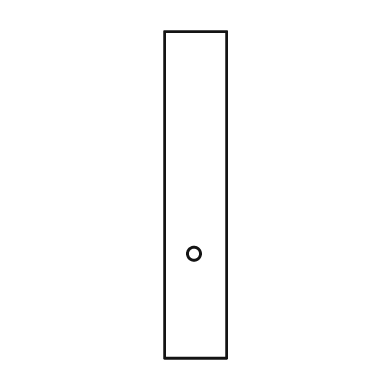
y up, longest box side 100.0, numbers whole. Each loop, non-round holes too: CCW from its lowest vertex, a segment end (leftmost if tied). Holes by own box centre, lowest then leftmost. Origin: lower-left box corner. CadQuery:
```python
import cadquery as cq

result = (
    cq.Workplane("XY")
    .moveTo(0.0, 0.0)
    .lineTo(19.0, 0.0)
    .lineTo(19.0, 100.0)
    .lineTo(0.0, 100.0)
    .close()
    .moveTo(9.0, 32.0)
    .circle(2.0)
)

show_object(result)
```